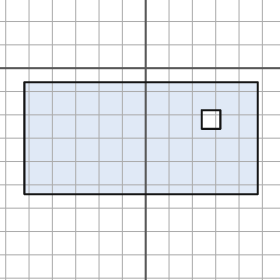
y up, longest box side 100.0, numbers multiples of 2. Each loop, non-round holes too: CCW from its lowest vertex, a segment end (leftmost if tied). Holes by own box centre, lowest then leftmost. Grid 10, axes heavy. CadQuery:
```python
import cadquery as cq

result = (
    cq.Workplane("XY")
    .moveTo(-52.0, -54.0)
    .lineTo(48.0, -54.0)
    .lineTo(48.0, -6.0)
    .lineTo(-52.0, -6.0)
    .close()
    .moveTo(24.0, -26.0)
    .lineTo(32.0, -26.0)
    .lineTo(32.0, -18.0)
    .lineTo(24.0, -18.0)
    .close()
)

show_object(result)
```